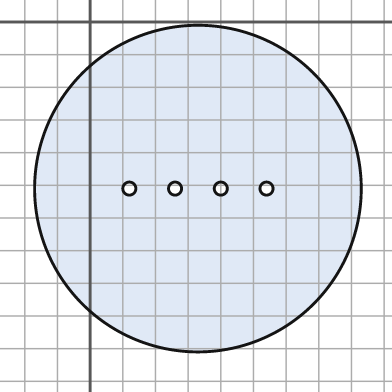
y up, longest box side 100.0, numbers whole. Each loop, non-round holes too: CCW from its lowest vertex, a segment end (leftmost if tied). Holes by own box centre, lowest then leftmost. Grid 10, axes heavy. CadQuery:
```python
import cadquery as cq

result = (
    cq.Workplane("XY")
    .moveTo(33.0, -51.0)
    .circle(50.0)
    .moveTo(12.0, -51.0)
    .circle(2.0)
    .moveTo(26.0, -51.0)
    .circle(2.0)
    .moveTo(40.0, -51.0)
    .circle(2.0)
    .moveTo(54.0, -51.0)
    .circle(2.0)
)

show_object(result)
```